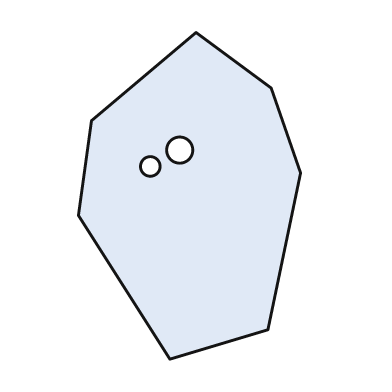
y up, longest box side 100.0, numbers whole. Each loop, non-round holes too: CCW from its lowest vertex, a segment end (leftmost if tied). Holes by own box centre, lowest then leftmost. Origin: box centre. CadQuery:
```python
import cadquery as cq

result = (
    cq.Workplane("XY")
    .moveTo(-6.0, -50.0)
    .lineTo(24.0, -41.0)
    .lineTo(34.0, 7.0)
    .lineTo(25.0, 33.0)
    .lineTo(2.0, 50.0)
    .lineTo(-30.0, 23.0)
    .lineTo(-34.0, -6.0)
    .close()
    .moveTo(-12.0, 9.0)
    .circle(3.0)
    .moveTo(-3.0, 14.0)
    .circle(4.0)
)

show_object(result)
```